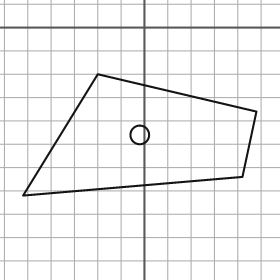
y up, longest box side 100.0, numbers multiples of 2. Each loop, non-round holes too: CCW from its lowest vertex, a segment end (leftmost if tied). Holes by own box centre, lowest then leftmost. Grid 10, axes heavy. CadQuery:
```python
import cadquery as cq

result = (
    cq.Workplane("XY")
    .moveTo(-52.0, -72.0)
    .lineTo(42.0, -64.0)
    .lineTo(48.0, -36.0)
    .lineTo(-20.0, -20.0)
    .close()
    .moveTo(-2.0, -46.0)
    .circle(4.0)
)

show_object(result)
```